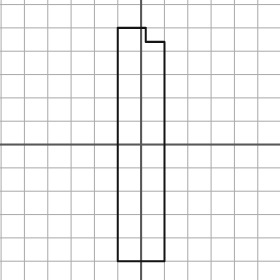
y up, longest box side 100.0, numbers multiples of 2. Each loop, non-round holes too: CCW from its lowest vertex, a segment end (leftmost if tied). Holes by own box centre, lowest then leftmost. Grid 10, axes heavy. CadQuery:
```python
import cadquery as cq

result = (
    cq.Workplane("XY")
    .moveTo(-10.0, -50.0)
    .lineTo(10.0, -50.0)
    .lineTo(10.0, 44.0)
    .lineTo(2.0, 44.0)
    .lineTo(2.0, 50.0)
    .lineTo(-10.0, 50.0)
    .close()
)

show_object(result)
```